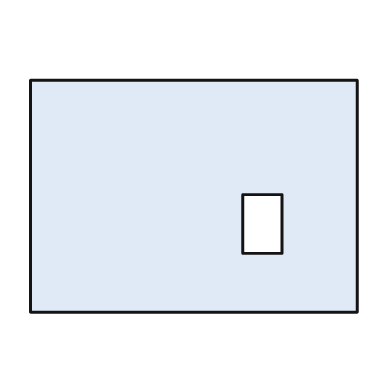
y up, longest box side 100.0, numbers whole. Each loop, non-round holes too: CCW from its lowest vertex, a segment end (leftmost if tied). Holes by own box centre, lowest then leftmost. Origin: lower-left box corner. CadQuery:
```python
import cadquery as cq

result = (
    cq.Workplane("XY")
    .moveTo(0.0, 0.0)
    .lineTo(100.0, 0.0)
    .lineTo(100.0, 71.0)
    .lineTo(0.0, 71.0)
    .close()
    .moveTo(65.0, 18.0)
    .lineTo(77.0, 18.0)
    .lineTo(77.0, 36.0)
    .lineTo(65.0, 36.0)
    .close()
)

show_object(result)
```